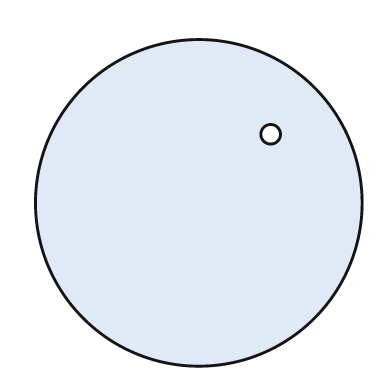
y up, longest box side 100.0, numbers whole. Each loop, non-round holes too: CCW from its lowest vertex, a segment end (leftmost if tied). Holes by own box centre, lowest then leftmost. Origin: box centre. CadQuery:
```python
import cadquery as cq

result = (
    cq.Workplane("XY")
    .moveTo(0.0, 0.0)
    .circle(50.0)
    .moveTo(22.0, 21.0)
    .circle(3.0)
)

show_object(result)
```